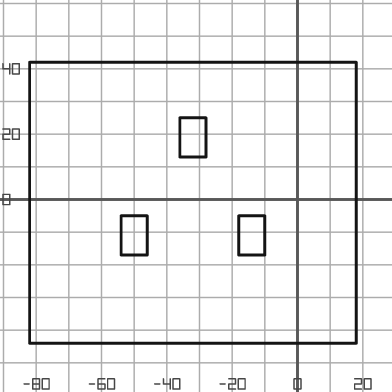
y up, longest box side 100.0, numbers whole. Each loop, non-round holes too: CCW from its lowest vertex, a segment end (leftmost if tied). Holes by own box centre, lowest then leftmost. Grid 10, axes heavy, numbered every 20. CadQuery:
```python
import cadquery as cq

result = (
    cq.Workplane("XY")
    .moveTo(-82.0, -44.0)
    .lineTo(18.0, -44.0)
    .lineTo(18.0, 42.0)
    .lineTo(-82.0, 42.0)
    .close()
    .moveTo(-54.0, -17.0)
    .lineTo(-46.0, -17.0)
    .lineTo(-46.0, -5.0)
    .lineTo(-54.0, -5.0)
    .close()
    .moveTo(-18.0, -17.0)
    .lineTo(-10.0, -17.0)
    .lineTo(-10.0, -5.0)
    .lineTo(-18.0, -5.0)
    .close()
    .moveTo(-36.0, 13.0)
    .lineTo(-28.0, 13.0)
    .lineTo(-28.0, 25.0)
    .lineTo(-36.0, 25.0)
    .close()
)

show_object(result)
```